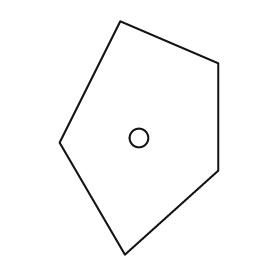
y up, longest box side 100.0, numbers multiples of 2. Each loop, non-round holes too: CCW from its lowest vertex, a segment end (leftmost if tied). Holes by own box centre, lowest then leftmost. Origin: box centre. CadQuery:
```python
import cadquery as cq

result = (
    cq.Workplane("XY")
    .moveTo(-6.0, -50.0)
    .lineTo(34.0, -14.0)
    .lineTo(34.0, 32.0)
    .lineTo(-8.0, 50.0)
    .lineTo(-34.0, -2.0)
    .close()
    .moveTo(0.0, 0.0)
    .circle(4.0)
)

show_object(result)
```